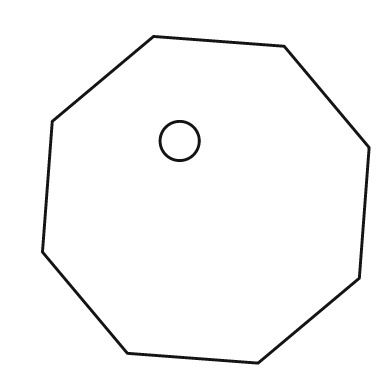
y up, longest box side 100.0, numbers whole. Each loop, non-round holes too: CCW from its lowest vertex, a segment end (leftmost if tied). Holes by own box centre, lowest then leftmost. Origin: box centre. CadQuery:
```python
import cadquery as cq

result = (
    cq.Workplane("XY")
    .moveTo(16.0, -50.0)
    .lineTo(47.0, -24.0)
    .lineTo(50.0, 16.0)
    .lineTo(24.0, 47.0)
    .lineTo(-16.0, 50.0)
    .lineTo(-47.0, 24.0)
    .lineTo(-50.0, -16.0)
    .lineTo(-24.0, -47.0)
    .close()
    .moveTo(-8.0, 18.0)
    .circle(6.0)
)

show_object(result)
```